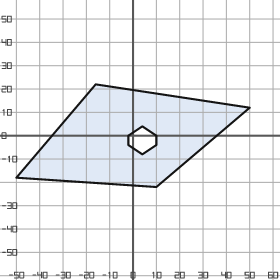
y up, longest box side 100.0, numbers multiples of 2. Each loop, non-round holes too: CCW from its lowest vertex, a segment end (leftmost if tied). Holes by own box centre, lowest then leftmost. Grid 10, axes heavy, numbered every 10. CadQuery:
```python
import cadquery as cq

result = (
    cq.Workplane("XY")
    .moveTo(10.0, -22.0)
    .lineTo(50.0, 12.0)
    .lineTo(-16.0, 22.0)
    .lineTo(-50.0, -18.0)
    .close()
    .moveTo(4.0, -8.0)
    .lineTo(10.0, -4.0)
    .lineTo(10.0, 0.0)
    .lineTo(4.0, 4.0)
    .lineTo(-2.0, 0.0)
    .lineTo(-2.0, -4.0)
    .close()
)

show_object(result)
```